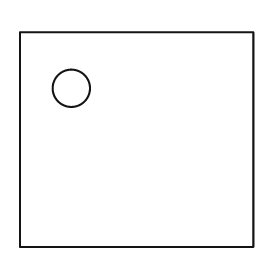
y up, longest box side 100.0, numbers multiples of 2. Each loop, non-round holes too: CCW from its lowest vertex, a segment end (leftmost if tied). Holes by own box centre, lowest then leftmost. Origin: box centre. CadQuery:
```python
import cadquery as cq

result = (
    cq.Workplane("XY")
    .moveTo(-50.0, -46.0)
    .lineTo(50.0, -46.0)
    .lineTo(50.0, 46.0)
    .lineTo(-50.0, 46.0)
    .close()
    .moveTo(-28.0, 22.0)
    .circle(8.0)
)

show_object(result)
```